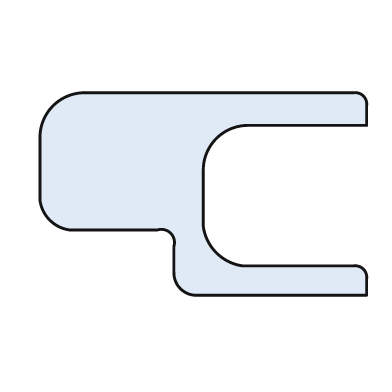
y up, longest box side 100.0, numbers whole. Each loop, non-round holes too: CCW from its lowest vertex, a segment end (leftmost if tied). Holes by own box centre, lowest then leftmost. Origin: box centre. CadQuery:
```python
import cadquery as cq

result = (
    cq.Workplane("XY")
    .moveTo(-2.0, -31.0)
    .lineTo(50.0, -31.0)
    .lineTo(50.0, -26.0)
    .threePointArc((49.0, -23.0), (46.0, -22.0))
    .lineTo(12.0, -22.0)
    .threePointArc((4.0, -18.0), (0.0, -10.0))
    .lineTo(0.0, 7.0)
    .threePointArc((4.0, 17.0), (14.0, 21.0))
    .lineTo(50.0, 21.0)
    .lineTo(50.0, 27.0)
    .threePointArc((49.0, 30.0), (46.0, 31.0))
    .lineTo(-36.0, 31.0)
    .threePointArc((-46.0, 27.0), (-50.0, 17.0))
    .lineTo(-50.0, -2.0)
    .threePointArc((-47.0, -8.0), (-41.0, -11.0))
    .lineTo(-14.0, -11.0)
    .threePointArc((-10.0, -12.0), (-9.0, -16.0))
    .lineTo(-9.0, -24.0)
    .threePointArc((-7.0, -29.0), (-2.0, -31.0))
    .close()
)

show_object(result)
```